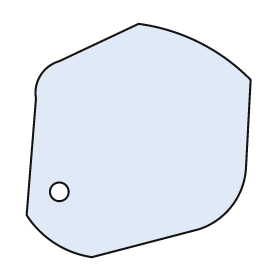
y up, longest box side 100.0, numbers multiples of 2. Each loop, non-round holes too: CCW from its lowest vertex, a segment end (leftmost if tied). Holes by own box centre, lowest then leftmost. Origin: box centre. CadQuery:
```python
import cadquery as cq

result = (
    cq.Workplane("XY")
    .moveTo(-20.0, -50.0)
    .lineTo(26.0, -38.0)
    .threePointArc((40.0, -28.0), (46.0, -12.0))
    .lineTo(48.0, 26.0)
    .threePointArc((26.0, 42.0), (0.0, 50.0))
    .lineTo(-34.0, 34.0)
    .threePointArc((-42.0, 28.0), (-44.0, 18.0))
    .lineTo(-48.0, -32.0)
    .threePointArc((-36.0, -44.0), (-20.0, -50.0))
    .close()
    .moveTo(-34.0, -22.0)
    .circle(4.0)
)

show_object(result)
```